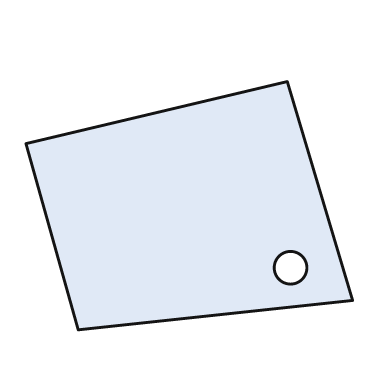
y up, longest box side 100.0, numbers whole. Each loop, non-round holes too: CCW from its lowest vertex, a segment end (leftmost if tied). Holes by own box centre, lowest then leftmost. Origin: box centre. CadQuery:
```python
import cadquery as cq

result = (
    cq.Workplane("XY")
    .moveTo(-34.0, -38.0)
    .lineTo(50.0, -29.0)
    .lineTo(30.0, 38.0)
    .lineTo(-50.0, 19.0)
    .close()
    .moveTo(31.0, -19.0)
    .circle(5.0)
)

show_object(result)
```